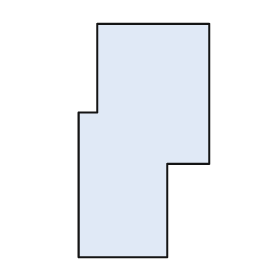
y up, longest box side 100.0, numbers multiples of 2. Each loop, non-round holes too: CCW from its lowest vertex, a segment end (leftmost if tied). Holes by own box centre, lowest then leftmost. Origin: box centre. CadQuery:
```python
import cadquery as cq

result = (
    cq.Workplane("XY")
    .moveTo(-28.0, -50.0)
    .lineTo(10.0, -50.0)
    .lineTo(10.0, -10.0)
    .lineTo(28.0, -10.0)
    .lineTo(28.0, 50.0)
    .lineTo(-20.0, 50.0)
    .lineTo(-20.0, 12.0)
    .lineTo(-28.0, 12.0)
    .close()
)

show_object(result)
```